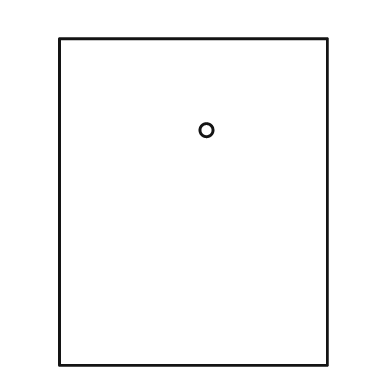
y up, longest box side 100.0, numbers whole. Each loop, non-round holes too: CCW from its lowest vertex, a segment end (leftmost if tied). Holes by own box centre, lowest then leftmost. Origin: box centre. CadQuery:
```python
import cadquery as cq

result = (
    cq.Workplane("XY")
    .moveTo(-41.0, -50.0)
    .lineTo(41.0, -50.0)
    .lineTo(41.0, 50.0)
    .lineTo(-41.0, 50.0)
    .close()
    .moveTo(4.0, 22.0)
    .circle(2.0)
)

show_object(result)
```